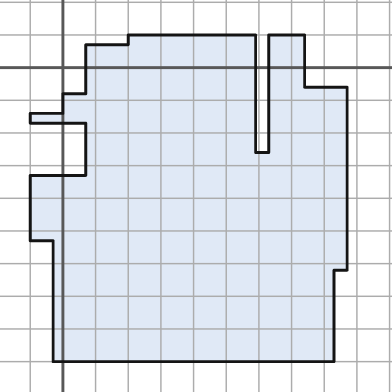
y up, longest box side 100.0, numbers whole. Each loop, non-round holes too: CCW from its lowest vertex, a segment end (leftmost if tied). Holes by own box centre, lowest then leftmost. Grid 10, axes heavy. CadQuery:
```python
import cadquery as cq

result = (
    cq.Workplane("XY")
    .moveTo(-3.0, -90.0)
    .lineTo(83.0, -90.0)
    .lineTo(83.0, -62.0)
    .lineTo(87.0, -62.0)
    .lineTo(87.0, -6.0)
    .lineTo(74.0, -6.0)
    .lineTo(74.0, 10.0)
    .lineTo(63.0, 10.0)
    .lineTo(63.0, -26.0)
    .lineTo(59.0, -26.0)
    .lineTo(59.0, 10.0)
    .lineTo(20.0, 10.0)
    .lineTo(20.0, 7.0)
    .lineTo(7.0, 7.0)
    .lineTo(7.0, -8.0)
    .lineTo(0.0, -8.0)
    .lineTo(0.0, -14.0)
    .lineTo(-10.0, -14.0)
    .lineTo(-10.0, -17.0)
    .lineTo(7.0, -17.0)
    .lineTo(7.0, -33.0)
    .lineTo(-10.0, -33.0)
    .lineTo(-10.0, -53.0)
    .lineTo(-3.0, -53.0)
    .close()
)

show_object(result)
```